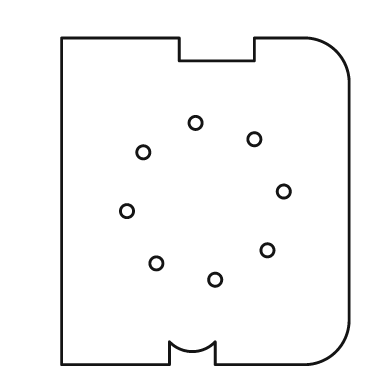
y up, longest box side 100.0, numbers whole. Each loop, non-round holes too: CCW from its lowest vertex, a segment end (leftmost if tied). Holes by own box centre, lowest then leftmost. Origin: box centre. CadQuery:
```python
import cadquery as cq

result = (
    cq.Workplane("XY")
    .moveTo(-44.0, -50.0)
    .lineTo(-11.0, -50.0)
    .lineTo(-11.0, -43.0)
    .threePointArc((-4.0, -46.0), (3.0, -43.0))
    .lineTo(3.0, -50.0)
    .lineTo(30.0, -50.0)
    .threePointArc((40.0, -46.0), (44.0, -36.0))
    .lineTo(44.0, 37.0)
    .threePointArc((40.0, 46.0), (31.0, 50.0))
    .lineTo(15.0, 50.0)
    .lineTo(15.0, 43.0)
    .lineTo(-8.0, 43.0)
    .lineTo(-8.0, 50.0)
    .lineTo(-44.0, 50.0)
    .close()
    .moveTo(3.0, -24.0)
    .circle(2.0)
    .moveTo(-15.0, -19.0)
    .circle(2.0)
    .moveTo(19.0, -15.0)
    .circle(2.0)
    .moveTo(-24.0, -3.0)
    .circle(2.0)
    .moveTo(24.0, 3.0)
    .circle(2.0)
    .moveTo(-19.0, 15.0)
    .circle(2.0)
    .moveTo(15.0, 19.0)
    .circle(2.0)
    .moveTo(-3.0, 24.0)
    .circle(2.0)
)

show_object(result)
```